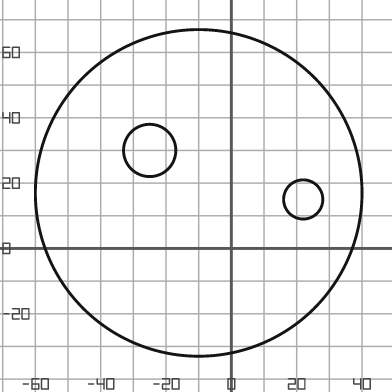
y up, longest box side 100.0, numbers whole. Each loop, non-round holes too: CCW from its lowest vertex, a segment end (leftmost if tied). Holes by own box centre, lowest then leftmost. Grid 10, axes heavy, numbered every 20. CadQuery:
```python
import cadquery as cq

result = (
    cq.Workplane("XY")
    .moveTo(-10.0, 17.0)
    .circle(50.0)
    .moveTo(22.0, 15.0)
    .circle(6.0)
    .moveTo(-25.0, 30.0)
    .circle(8.0)
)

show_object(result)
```